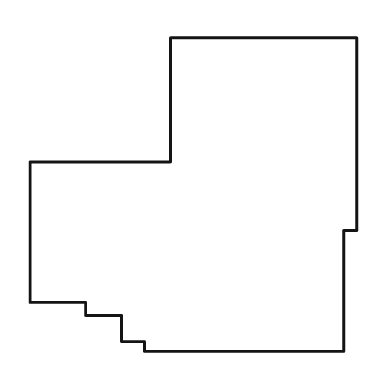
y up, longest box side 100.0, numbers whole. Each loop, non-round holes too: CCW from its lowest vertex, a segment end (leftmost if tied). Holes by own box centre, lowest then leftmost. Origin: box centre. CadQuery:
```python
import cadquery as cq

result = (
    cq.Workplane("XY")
    .moveTo(-15.0, -48.0)
    .lineTo(46.0, -48.0)
    .lineTo(46.0, -11.0)
    .lineTo(50.0, -11.0)
    .lineTo(50.0, 48.0)
    .lineTo(-7.0, 48.0)
    .lineTo(-7.0, 10.0)
    .lineTo(-50.0, 10.0)
    .lineTo(-50.0, -33.0)
    .lineTo(-33.0, -33.0)
    .lineTo(-33.0, -37.0)
    .lineTo(-22.0, -37.0)
    .lineTo(-22.0, -45.0)
    .lineTo(-15.0, -45.0)
    .close()
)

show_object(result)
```